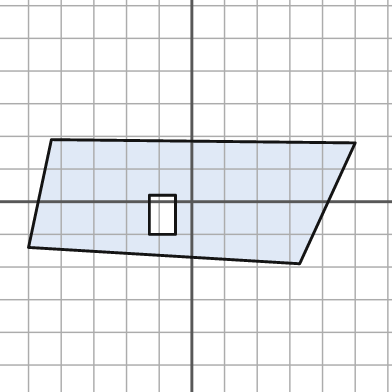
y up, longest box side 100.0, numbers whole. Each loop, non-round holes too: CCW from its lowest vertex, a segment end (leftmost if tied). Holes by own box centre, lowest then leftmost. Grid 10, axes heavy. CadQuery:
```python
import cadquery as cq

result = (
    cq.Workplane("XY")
    .moveTo(33.0, -19.0)
    .lineTo(50.0, 18.0)
    .lineTo(-43.0, 19.0)
    .lineTo(-50.0, -14.0)
    .close()
    .moveTo(-13.0, -10.0)
    .lineTo(-5.0, -10.0)
    .lineTo(-5.0, 2.0)
    .lineTo(-13.0, 2.0)
    .close()
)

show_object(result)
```